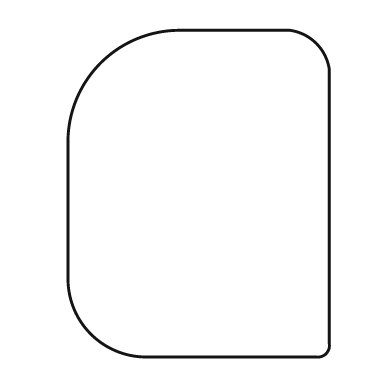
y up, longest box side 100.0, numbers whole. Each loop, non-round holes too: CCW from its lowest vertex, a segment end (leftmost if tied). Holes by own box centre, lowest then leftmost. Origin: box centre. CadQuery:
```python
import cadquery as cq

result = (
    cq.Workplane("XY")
    .moveTo(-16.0, -50.0)
    .lineTo(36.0, -50.0)
    .threePointArc((39.0, -49.0), (40.0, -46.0))
    .lineTo(40.0, 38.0)
    .threePointArc((36.0, 46.0), (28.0, 50.0))
    .lineTo(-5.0, 50.0)
    .threePointArc((-30.0, 40.0), (-40.0, 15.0))
    .lineTo(-40.0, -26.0)
    .threePointArc((-33.0, -43.0), (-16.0, -50.0))
    .close()
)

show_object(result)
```